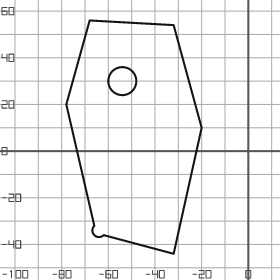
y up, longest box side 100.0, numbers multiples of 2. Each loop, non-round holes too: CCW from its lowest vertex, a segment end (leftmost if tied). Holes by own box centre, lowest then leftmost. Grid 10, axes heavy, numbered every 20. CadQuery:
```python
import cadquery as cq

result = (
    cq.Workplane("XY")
    .moveTo(-32.0, -44.0)
    .lineTo(-20.0, 10.0)
    .lineTo(-32.0, 54.0)
    .lineTo(-68.0, 56.0)
    .lineTo(-78.0, 20.0)
    .lineTo(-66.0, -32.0)
    .threePointArc((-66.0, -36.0), (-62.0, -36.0))
    .close()
    .moveTo(-54.0, 30.0)
    .circle(6.0)
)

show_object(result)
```